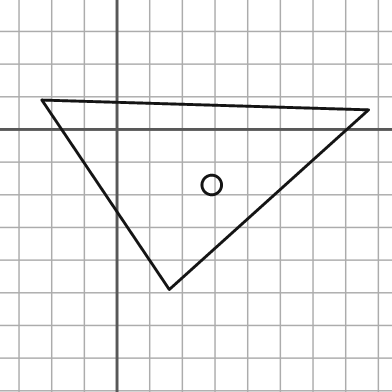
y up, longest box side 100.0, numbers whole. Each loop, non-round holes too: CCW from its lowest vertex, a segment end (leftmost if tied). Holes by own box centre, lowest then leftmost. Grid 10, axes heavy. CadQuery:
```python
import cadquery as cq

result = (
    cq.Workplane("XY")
    .moveTo(16.0, -49.0)
    .lineTo(77.0, 6.0)
    .lineTo(-23.0, 9.0)
    .close()
    .moveTo(29.0, -17.0)
    .circle(3.0)
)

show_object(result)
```